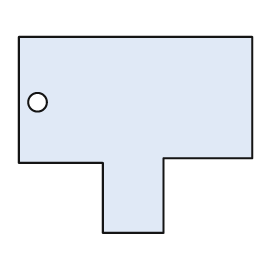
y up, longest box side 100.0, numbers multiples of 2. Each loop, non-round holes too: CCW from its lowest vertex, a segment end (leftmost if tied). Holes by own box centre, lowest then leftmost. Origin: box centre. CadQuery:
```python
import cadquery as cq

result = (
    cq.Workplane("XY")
    .moveTo(-14.0, -42.0)
    .lineTo(12.0, -42.0)
    .lineTo(12.0, -10.0)
    .lineTo(50.0, -10.0)
    .lineTo(50.0, 42.0)
    .lineTo(-50.0, 42.0)
    .lineTo(-50.0, -12.0)
    .lineTo(-14.0, -12.0)
    .close()
    .moveTo(-42.0, 14.0)
    .circle(4.0)
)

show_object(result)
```